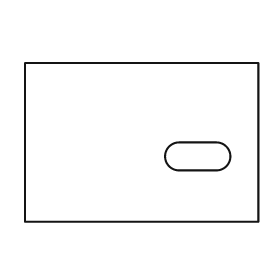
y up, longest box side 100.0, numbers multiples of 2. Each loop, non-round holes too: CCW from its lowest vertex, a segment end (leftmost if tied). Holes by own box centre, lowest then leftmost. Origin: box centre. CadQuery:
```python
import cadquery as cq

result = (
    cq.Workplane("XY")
    .moveTo(-50.0, -34.0)
    .lineTo(50.0, -34.0)
    .lineTo(50.0, 34.0)
    .lineTo(-50.0, 34.0)
    .close()
    .moveTo(16.0, -12.0)
    .lineTo(32.0, -12.0)
    .threePointArc((38.0, -6.0), (32.0, 0.0))
    .lineTo(16.0, 0.0)
    .threePointArc((10.0, -6.0), (16.0, -12.0))
    .close()
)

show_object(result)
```